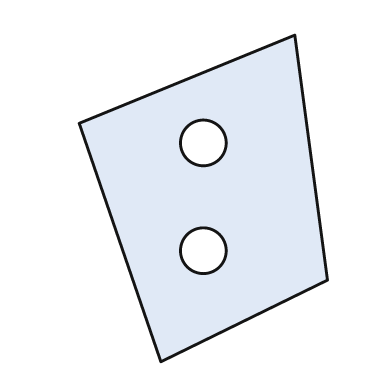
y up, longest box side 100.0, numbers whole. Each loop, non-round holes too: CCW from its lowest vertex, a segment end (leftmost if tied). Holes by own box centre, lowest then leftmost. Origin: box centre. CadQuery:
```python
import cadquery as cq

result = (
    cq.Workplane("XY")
    .moveTo(-13.0, -50.0)
    .lineTo(38.0, -25.0)
    .lineTo(28.0, 50.0)
    .lineTo(-38.0, 23.0)
    .close()
    .moveTo(0.0, -16.0)
    .circle(7.0)
    .moveTo(0.0, 17.0)
    .circle(7.0)
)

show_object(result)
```